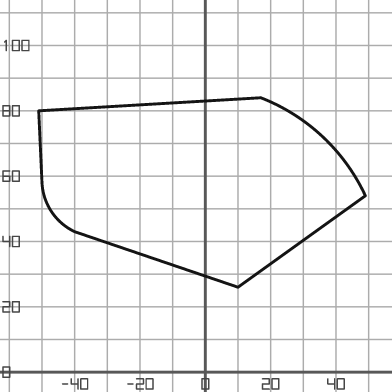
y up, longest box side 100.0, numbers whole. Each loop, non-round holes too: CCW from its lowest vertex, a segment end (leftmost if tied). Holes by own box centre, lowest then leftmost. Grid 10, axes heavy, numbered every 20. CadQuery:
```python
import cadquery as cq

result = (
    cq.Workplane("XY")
    .moveTo(10.0, 26.0)
    .lineTo(49.0, 54.0)
    .threePointArc((36.0, 72.0), (17.0, 84.0))
    .lineTo(-51.0, 80.0)
    .lineTo(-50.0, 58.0)
    .threePointArc((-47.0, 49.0), (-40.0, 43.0))
    .close()
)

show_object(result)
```